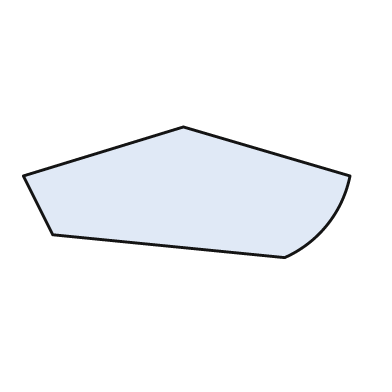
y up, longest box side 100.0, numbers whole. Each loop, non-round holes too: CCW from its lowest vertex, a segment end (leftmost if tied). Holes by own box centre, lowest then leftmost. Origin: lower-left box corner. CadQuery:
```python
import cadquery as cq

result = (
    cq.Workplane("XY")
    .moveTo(80.0, 0.0)
    .threePointArc((93.0, 10.0), (100.0, 25.0))
    .lineTo(49.0, 40.0)
    .lineTo(0.0, 25.0)
    .lineTo(9.0, 7.0)
    .close()
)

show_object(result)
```